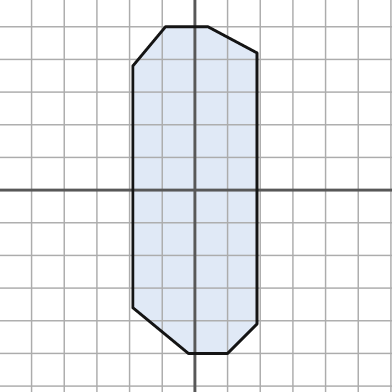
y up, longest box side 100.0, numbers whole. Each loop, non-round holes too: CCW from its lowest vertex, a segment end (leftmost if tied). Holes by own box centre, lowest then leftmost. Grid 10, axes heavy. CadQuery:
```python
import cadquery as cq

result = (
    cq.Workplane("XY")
    .moveTo(-2.0, -50.0)
    .lineTo(10.0, -50.0)
    .lineTo(19.0, -41.0)
    .lineTo(19.0, 42.0)
    .lineTo(4.0, 50.0)
    .lineTo(-9.0, 50.0)
    .lineTo(-19.0, 38.0)
    .lineTo(-19.0, -36.0)
    .close()
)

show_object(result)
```